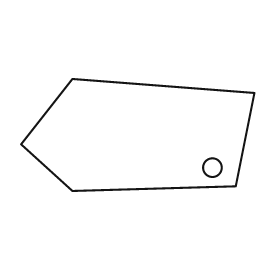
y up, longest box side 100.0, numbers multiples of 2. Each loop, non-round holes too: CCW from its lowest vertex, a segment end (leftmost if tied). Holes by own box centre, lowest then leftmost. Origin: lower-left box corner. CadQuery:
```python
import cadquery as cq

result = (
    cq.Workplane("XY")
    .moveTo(22.0, 0.0)
    .lineTo(92.0, 2.0)
    .lineTo(100.0, 42.0)
    .lineTo(22.0, 48.0)
    .lineTo(0.0, 20.0)
    .close()
    .moveTo(82.0, 10.0)
    .circle(4.0)
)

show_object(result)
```